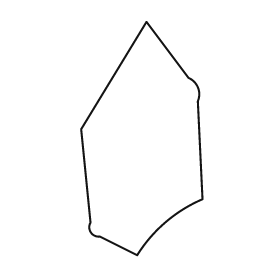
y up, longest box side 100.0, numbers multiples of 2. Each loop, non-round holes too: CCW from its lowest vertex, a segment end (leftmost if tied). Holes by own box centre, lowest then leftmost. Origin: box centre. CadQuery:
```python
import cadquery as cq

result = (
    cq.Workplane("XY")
    .moveTo(-2.0, -50.0)
    .threePointArc((10.0, -36.0), (26.0, -26.0))
    .lineTo(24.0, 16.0)
    .threePointArc((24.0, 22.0), (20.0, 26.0))
    .lineTo(2.0, 50.0)
    .lineTo(-26.0, 4.0)
    .lineTo(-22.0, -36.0)
    .threePointArc((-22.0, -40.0), (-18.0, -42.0))
    .close()
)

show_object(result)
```